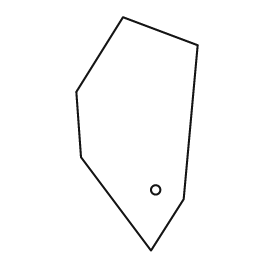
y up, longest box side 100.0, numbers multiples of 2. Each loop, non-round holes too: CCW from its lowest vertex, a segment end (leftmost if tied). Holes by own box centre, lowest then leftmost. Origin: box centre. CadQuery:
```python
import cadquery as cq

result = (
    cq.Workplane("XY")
    .moveTo(6.0, -50.0)
    .lineTo(20.0, -28.0)
    .lineTo(26.0, 38.0)
    .lineTo(-6.0, 50.0)
    .lineTo(-26.0, 18.0)
    .lineTo(-24.0, -10.0)
    .close()
    .moveTo(8.0, -24.0)
    .circle(2.0)
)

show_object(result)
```